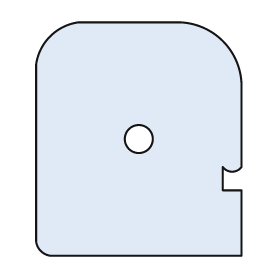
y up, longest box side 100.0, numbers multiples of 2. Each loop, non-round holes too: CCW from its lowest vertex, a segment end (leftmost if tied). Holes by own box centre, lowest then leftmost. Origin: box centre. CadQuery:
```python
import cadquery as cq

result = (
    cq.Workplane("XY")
    .moveTo(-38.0, -50.0)
    .lineTo(44.0, -50.0)
    .lineTo(44.0, -22.0)
    .lineTo(36.0, -22.0)
    .lineTo(36.0, -12.0)
    .threePointArc((40.0, -14.0), (44.0, -12.0))
    .lineTo(44.0, 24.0)
    .threePointArc((36.0, 42.0), (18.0, 50.0))
    .lineTo(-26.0, 50.0)
    .threePointArc((-38.0, 44.0), (-44.0, 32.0))
    .lineTo(-44.0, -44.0)
    .threePointArc((-42.0, -48.0), (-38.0, -50.0))
    .close()
    .moveTo(0.0, 0.0)
    .circle(6.0)
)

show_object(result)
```